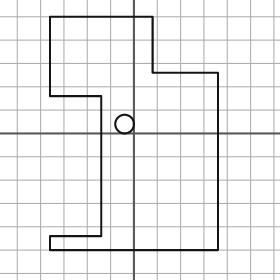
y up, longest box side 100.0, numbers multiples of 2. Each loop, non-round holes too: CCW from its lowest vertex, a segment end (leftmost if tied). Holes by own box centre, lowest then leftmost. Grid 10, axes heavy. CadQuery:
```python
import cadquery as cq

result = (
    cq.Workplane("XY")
    .moveTo(-36.0, -50.0)
    .lineTo(36.0, -50.0)
    .lineTo(36.0, 26.0)
    .lineTo(8.0, 26.0)
    .lineTo(8.0, 50.0)
    .lineTo(-36.0, 50.0)
    .lineTo(-36.0, 16.0)
    .lineTo(-14.0, 16.0)
    .lineTo(-14.0, -44.0)
    .lineTo(-36.0, -44.0)
    .close()
    .moveTo(-4.0, 4.0)
    .circle(4.0)
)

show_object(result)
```